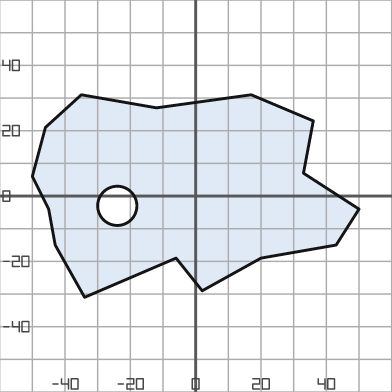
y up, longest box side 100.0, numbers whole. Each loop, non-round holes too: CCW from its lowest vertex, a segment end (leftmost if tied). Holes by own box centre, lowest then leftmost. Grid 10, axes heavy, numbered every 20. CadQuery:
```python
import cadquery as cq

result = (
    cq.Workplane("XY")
    .moveTo(-34.0, -31.0)
    .lineTo(-6.0, -19.0)
    .lineTo(2.0, -29.0)
    .lineTo(20.0, -19.0)
    .lineTo(43.0, -15.0)
    .lineTo(50.0, -4.0)
    .lineTo(33.0, 7.0)
    .lineTo(36.0, 23.0)
    .lineTo(17.0, 31.0)
    .lineTo(-12.0, 27.0)
    .lineTo(-35.0, 31.0)
    .lineTo(-46.0, 21.0)
    .lineTo(-50.0, 6.0)
    .lineTo(-45.0, -4.0)
    .lineTo(-43.0, -15.0)
    .close()
    .moveTo(-24.0, -3.0)
    .circle(6.0)
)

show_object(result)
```